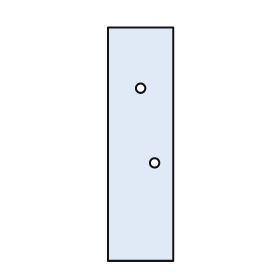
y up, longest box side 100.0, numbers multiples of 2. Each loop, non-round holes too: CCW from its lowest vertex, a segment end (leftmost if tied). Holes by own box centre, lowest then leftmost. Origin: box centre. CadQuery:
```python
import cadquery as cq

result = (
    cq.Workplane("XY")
    .moveTo(-14.0, -50.0)
    .lineTo(14.0, -50.0)
    .lineTo(14.0, 50.0)
    .lineTo(-14.0, 50.0)
    .close()
    .moveTo(6.0, -8.0)
    .circle(2.0)
    .moveTo(0.0, 24.0)
    .circle(2.0)
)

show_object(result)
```